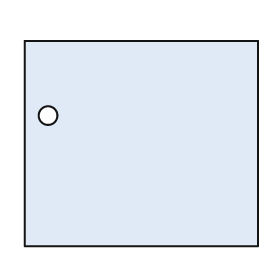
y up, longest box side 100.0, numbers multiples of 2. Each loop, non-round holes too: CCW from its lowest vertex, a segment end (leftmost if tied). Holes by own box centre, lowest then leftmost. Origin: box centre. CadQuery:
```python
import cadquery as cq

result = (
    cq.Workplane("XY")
    .moveTo(-50.0, -44.0)
    .lineTo(50.0, -44.0)
    .lineTo(50.0, 44.0)
    .lineTo(-50.0, 44.0)
    .close()
    .moveTo(-40.0, 12.0)
    .circle(4.0)
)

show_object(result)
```